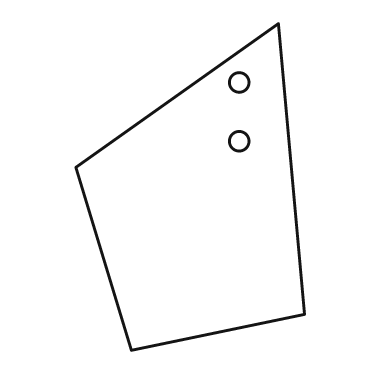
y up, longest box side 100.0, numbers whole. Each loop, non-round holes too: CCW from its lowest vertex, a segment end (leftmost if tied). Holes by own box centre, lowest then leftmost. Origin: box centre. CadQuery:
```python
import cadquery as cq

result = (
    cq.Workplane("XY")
    .moveTo(-18.0, -50.0)
    .lineTo(35.0, -39.0)
    .lineTo(27.0, 50.0)
    .lineTo(-35.0, 6.0)
    .close()
    .moveTo(15.0, 14.0)
    .circle(3.0)
    .moveTo(15.0, 32.0)
    .circle(3.0)
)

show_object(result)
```